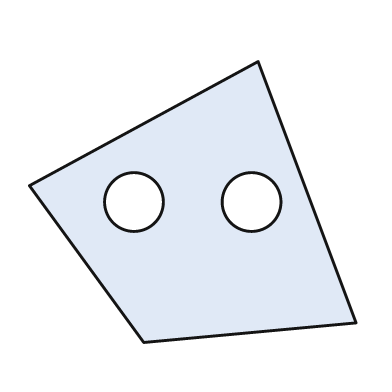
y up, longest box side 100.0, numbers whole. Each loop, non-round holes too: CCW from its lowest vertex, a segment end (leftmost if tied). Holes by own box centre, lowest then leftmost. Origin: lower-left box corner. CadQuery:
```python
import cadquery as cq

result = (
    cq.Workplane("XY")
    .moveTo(35.0, 0.0)
    .lineTo(100.0, 6.0)
    .lineTo(70.0, 86.0)
    .lineTo(0.0, 48.0)
    .close()
    .moveTo(32.0, 43.0)
    .circle(9.0)
    .moveTo(68.0, 43.0)
    .circle(9.0)
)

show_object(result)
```